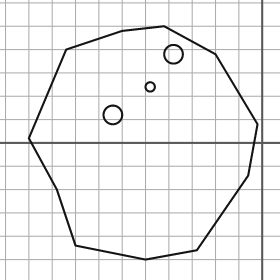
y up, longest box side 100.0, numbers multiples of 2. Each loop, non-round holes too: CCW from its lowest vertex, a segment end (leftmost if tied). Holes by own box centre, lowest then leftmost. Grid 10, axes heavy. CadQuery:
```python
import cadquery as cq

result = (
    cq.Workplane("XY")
    .moveTo(-50.0, -50.0)
    .lineTo(-28.0, -46.0)
    .lineTo(-6.0, -14.0)
    .lineTo(-2.0, 8.0)
    .lineTo(-20.0, 38.0)
    .lineTo(-42.0, 50.0)
    .lineTo(-60.0, 48.0)
    .lineTo(-84.0, 40.0)
    .lineTo(-100.0, 2.0)
    .lineTo(-88.0, -20.0)
    .lineTo(-80.0, -44.0)
    .close()
    .moveTo(-64.0, 12.0)
    .circle(4.0)
    .moveTo(-48.0, 24.0)
    .circle(2.0)
    .moveTo(-38.0, 38.0)
    .circle(4.0)
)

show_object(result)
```